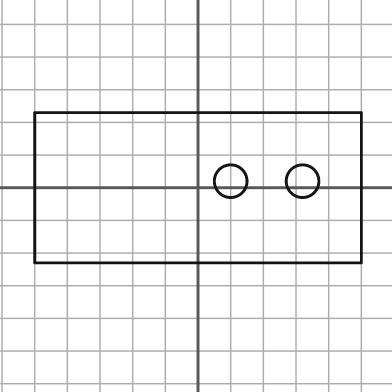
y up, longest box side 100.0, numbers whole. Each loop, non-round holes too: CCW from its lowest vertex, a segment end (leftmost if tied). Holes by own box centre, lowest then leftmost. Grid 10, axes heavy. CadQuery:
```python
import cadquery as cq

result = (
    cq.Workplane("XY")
    .moveTo(-50.0, -23.0)
    .lineTo(50.0, -23.0)
    .lineTo(50.0, 23.0)
    .lineTo(-50.0, 23.0)
    .close()
    .moveTo(10.0, 2.0)
    .circle(5.0)
    .moveTo(32.0, 2.0)
    .circle(5.0)
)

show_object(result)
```